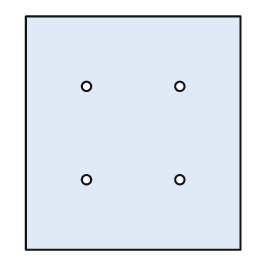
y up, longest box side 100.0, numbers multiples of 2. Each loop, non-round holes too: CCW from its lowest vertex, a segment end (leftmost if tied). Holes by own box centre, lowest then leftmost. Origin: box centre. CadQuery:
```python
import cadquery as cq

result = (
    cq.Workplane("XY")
    .moveTo(-46.0, -50.0)
    .lineTo(46.0, -50.0)
    .lineTo(46.0, 50.0)
    .lineTo(-46.0, 50.0)
    .close()
    .moveTo(-20.0, -20.0)
    .circle(2.0)
    .moveTo(20.0, -20.0)
    .circle(2.0)
    .moveTo(-20.0, 20.0)
    .circle(2.0)
    .moveTo(20.0, 20.0)
    .circle(2.0)
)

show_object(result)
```